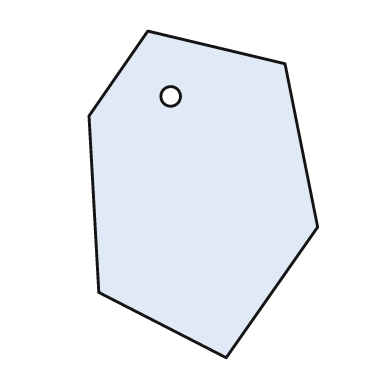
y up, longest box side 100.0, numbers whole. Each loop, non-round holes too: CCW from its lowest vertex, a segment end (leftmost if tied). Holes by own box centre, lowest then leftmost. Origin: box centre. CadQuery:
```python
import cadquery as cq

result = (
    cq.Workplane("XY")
    .moveTo(7.0, -50.0)
    .lineTo(35.0, -10.0)
    .lineTo(25.0, 40.0)
    .lineTo(-17.0, 50.0)
    .lineTo(-35.0, 24.0)
    .lineTo(-32.0, -30.0)
    .close()
    .moveTo(-10.0, 30.0)
    .circle(3.0)
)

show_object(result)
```